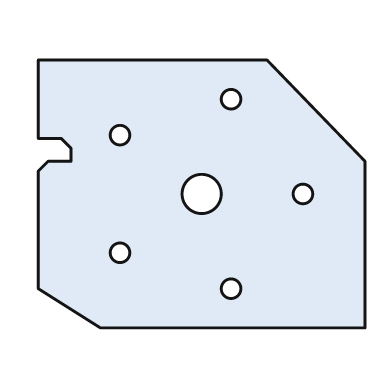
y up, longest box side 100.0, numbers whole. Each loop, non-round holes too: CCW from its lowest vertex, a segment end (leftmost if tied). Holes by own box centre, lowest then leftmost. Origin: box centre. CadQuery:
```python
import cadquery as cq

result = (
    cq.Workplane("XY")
    .moveTo(-31.0, -41.0)
    .lineTo(50.0, -41.0)
    .lineTo(50.0, 10.0)
    .lineTo(20.0, 41.0)
    .lineTo(-50.0, 41.0)
    .lineTo(-50.0, 17.0)
    .lineTo(-43.0, 17.0)
    .lineTo(-40.0, 14.0)
    .lineTo(-40.0, 10.0)
    .lineTo(-47.0, 10.0)
    .lineTo(-50.0, 7.0)
    .lineTo(-50.0, -29.0)
    .close()
    .moveTo(9.0, -29.0)
    .circle(3.0)
    .moveTo(-25.0, -18.0)
    .circle(3.0)
    .moveTo(0.0, 0.0)
    .circle(6.0)
    .moveTo(31.0, 0.0)
    .circle(3.0)
    .moveTo(-25.0, 18.0)
    .circle(3.0)
    .moveTo(9.0, 29.0)
    .circle(3.0)
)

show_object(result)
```